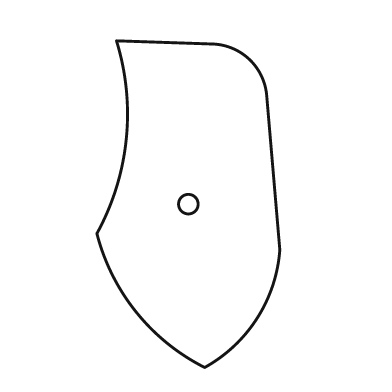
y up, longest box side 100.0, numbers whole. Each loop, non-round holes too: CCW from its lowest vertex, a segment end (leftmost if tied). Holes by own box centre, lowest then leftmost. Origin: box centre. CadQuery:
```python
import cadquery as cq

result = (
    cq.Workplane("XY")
    .moveTo(5.0, -50.0)
    .threePointArc((21.0, -35.0), (28.0, -14.0))
    .lineTo(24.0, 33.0)
    .threePointArc((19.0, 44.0), (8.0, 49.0))
    .lineTo(-22.0, 50.0)
    .threePointArc((-19.0, 20.0), (-28.0, -9.0))
    .threePointArc((-16.0, -33.0), (5.0, -50.0))
    .close()
    .moveTo(0.0, 0.0)
    .circle(3.0)
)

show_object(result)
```